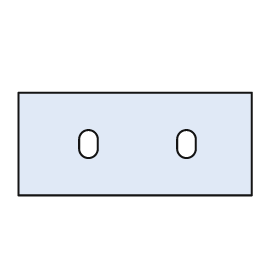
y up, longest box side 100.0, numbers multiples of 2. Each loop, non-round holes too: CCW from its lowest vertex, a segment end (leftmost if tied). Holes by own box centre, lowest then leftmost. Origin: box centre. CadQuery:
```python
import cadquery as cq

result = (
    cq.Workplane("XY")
    .moveTo(-50.0, -22.0)
    .lineTo(50.0, -22.0)
    .lineTo(50.0, 22.0)
    .lineTo(-50.0, 22.0)
    .close()
    .moveTo(-24.0, -2.0)
    .threePointArc((-20.0, -6.0), (-16.0, -2.0))
    .lineTo(-16.0, 2.0)
    .threePointArc((-20.0, 6.0), (-24.0, 2.0))
    .close()
    .moveTo(18.0, -2.0)
    .threePointArc((22.0, -6.0), (26.0, -2.0))
    .lineTo(26.0, 2.0)
    .threePointArc((22.0, 6.0), (18.0, 2.0))
    .close()
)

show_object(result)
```